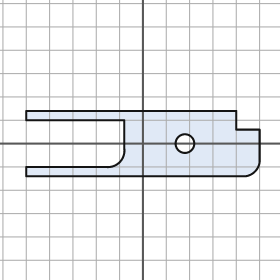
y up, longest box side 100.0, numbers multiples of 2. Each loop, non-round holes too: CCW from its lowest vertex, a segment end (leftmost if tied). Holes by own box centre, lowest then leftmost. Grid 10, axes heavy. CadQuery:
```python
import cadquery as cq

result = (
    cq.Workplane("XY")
    .moveTo(-50.0, -14.0)
    .lineTo(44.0, -14.0)
    .threePointArc((48.0, -12.0), (50.0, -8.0))
    .lineTo(50.0, 6.0)
    .lineTo(40.0, 6.0)
    .lineTo(40.0, 14.0)
    .lineTo(-50.0, 14.0)
    .lineTo(-50.0, 10.0)
    .lineTo(-8.0, 10.0)
    .lineTo(-8.0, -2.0)
    .threePointArc((-10.0, -8.0), (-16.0, -10.0))
    .lineTo(-50.0, -10.0)
    .close()
    .moveTo(18.0, 0.0)
    .circle(4.0)
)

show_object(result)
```